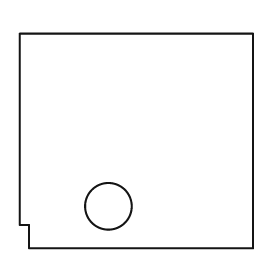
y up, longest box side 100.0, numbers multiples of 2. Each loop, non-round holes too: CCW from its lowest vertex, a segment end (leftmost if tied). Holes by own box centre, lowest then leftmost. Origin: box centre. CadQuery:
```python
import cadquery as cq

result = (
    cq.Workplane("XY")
    .moveTo(-46.0, -46.0)
    .lineTo(50.0, -46.0)
    .lineTo(50.0, 46.0)
    .lineTo(-50.0, 46.0)
    .lineTo(-50.0, -36.0)
    .lineTo(-46.0, -36.0)
    .close()
    .moveTo(-12.0, -28.0)
    .circle(10.0)
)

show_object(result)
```